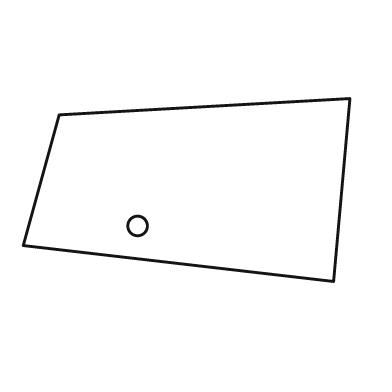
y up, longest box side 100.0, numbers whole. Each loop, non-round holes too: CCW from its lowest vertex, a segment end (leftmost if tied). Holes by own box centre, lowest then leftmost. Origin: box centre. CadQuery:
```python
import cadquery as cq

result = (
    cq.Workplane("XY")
    .moveTo(45.0, -28.0)
    .lineTo(50.0, 28.0)
    .lineTo(-39.0, 23.0)
    .lineTo(-50.0, -17.0)
    .close()
    .moveTo(-15.0, -11.0)
    .circle(3.0)
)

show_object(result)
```